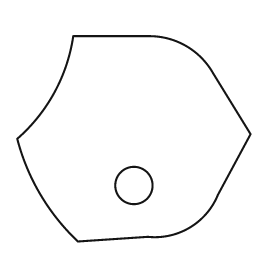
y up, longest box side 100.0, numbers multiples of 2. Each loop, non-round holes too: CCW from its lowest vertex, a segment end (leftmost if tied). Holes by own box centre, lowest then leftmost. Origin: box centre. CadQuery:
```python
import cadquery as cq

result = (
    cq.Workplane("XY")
    .moveTo(-24.0, -44.0)
    .lineTo(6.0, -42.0)
    .threePointArc((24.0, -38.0), (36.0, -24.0))
    .lineTo(50.0, 2.0)
    .lineTo(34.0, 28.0)
    .threePointArc((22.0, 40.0), (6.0, 44.0))
    .lineTo(-26.0, 44.0)
    .threePointArc((-34.0, 20.0), (-50.0, 0.0))
    .threePointArc((-40.0, -24.0), (-24.0, -44.0))
    .close()
    .moveTo(0.0, -20.0)
    .circle(8.0)
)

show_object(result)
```